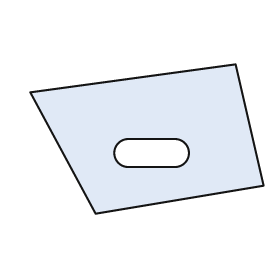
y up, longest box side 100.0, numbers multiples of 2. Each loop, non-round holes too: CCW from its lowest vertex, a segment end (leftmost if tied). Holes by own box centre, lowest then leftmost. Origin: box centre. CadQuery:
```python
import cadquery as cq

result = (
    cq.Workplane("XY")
    .moveTo(-22.0, -32.0)
    .lineTo(50.0, -20.0)
    .lineTo(38.0, 32.0)
    .lineTo(-50.0, 20.0)
    .close()
    .moveTo(-8.0, -12.0)
    .lineTo(12.0, -12.0)
    .threePointArc((18.0, -6.0), (12.0, 0.0))
    .lineTo(-8.0, 0.0)
    .threePointArc((-14.0, -6.0), (-8.0, -12.0))
    .close()
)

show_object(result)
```